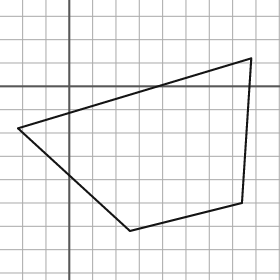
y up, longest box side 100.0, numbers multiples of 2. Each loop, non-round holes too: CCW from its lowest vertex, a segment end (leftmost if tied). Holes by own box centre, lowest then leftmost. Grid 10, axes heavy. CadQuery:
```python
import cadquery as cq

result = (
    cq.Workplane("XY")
    .moveTo(26.0, -62.0)
    .lineTo(74.0, -50.0)
    .lineTo(78.0, 12.0)
    .lineTo(-22.0, -18.0)
    .close()
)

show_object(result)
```